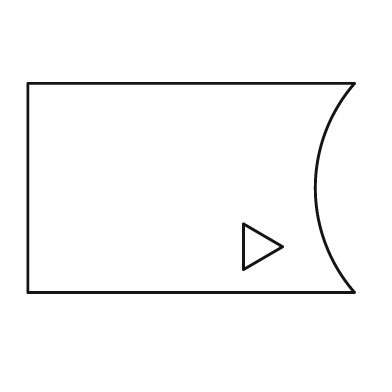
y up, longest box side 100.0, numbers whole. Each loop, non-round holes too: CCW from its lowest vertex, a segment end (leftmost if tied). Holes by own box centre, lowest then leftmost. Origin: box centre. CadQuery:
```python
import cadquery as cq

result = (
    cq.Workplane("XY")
    .moveTo(-50.0, -32.0)
    .lineTo(50.0, -32.0)
    .threePointArc((38.0, 0.0), (50.0, 32.0))
    .lineTo(-50.0, 32.0)
    .close()
    .moveTo(16.0, -25.0)
    .lineTo(28.0, -18.0)
    .lineTo(16.0, -11.0)
    .close()
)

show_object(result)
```